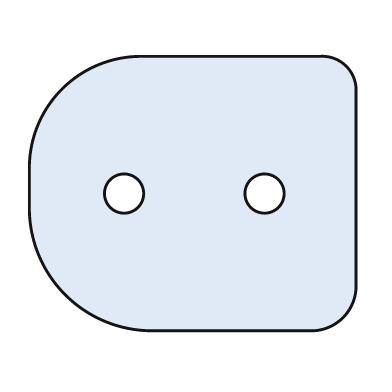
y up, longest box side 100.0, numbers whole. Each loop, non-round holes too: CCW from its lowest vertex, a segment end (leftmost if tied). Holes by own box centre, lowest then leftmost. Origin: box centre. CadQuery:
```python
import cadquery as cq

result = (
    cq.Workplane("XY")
    .moveTo(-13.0, -42.0)
    .lineTo(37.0, -42.0)
    .threePointArc((46.0, -38.0), (50.0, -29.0))
    .lineTo(50.0, 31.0)
    .threePointArc((47.0, 39.0), (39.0, 42.0))
    .lineTo(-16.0, 42.0)
    .threePointArc((-40.0, 32.0), (-50.0, 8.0))
    .lineTo(-50.0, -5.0)
    .threePointArc((-39.0, -31.0), (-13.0, -42.0))
    .close()
    .moveTo(-21.0, 0.0)
    .circle(6.0)
    .moveTo(22.0, 0.0)
    .circle(6.0)
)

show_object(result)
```